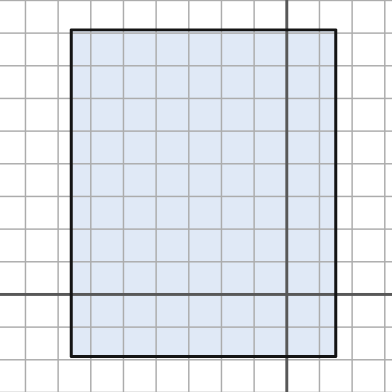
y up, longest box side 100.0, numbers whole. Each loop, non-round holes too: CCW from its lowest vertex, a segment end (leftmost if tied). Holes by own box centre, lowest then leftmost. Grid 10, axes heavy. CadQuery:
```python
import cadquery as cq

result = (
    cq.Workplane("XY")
    .moveTo(-66.0, -19.0)
    .lineTo(15.0, -19.0)
    .lineTo(15.0, 81.0)
    .lineTo(-66.0, 81.0)
    .close()
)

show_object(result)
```